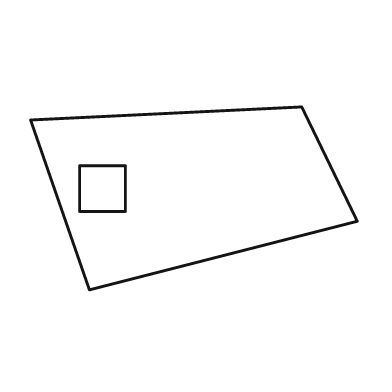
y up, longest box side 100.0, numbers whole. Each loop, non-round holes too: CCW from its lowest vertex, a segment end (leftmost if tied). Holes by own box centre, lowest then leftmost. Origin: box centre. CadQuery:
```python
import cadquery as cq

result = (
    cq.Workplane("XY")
    .moveTo(-32.0, -28.0)
    .lineTo(50.0, -7.0)
    .lineTo(33.0, 28.0)
    .lineTo(-50.0, 24.0)
    .close()
    .moveTo(-35.0, -4.0)
    .lineTo(-21.0, -4.0)
    .lineTo(-21.0, 10.0)
    .lineTo(-35.0, 10.0)
    .close()
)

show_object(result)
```